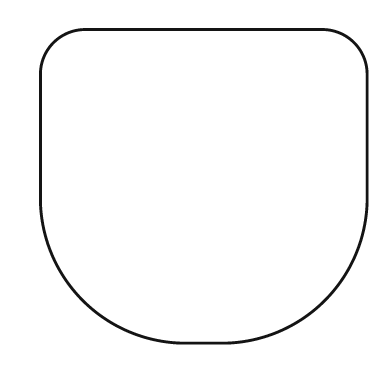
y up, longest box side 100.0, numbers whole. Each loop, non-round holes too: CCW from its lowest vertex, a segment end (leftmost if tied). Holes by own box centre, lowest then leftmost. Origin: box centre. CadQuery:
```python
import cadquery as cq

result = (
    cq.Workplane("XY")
    .moveTo(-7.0, -48.0)
    .lineTo(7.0, -48.0)
    .threePointArc((37.0, -35.0), (50.0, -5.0))
    .lineTo(50.0, 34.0)
    .threePointArc((46.0, 44.0), (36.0, 48.0))
    .lineTo(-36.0, 48.0)
    .threePointArc((-46.0, 44.0), (-50.0, 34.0))
    .lineTo(-50.0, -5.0)
    .threePointArc((-37.0, -35.0), (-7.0, -48.0))
    .close()
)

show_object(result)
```